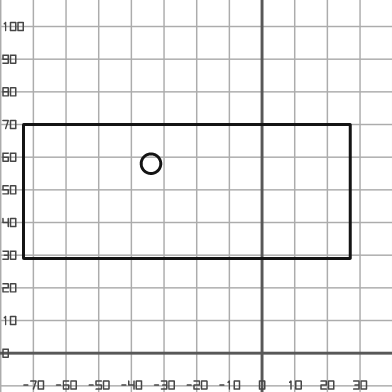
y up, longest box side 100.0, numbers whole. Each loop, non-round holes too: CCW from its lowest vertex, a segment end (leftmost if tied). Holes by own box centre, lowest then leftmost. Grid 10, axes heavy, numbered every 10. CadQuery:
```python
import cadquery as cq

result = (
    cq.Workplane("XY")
    .moveTo(-73.0, 29.0)
    .lineTo(27.0, 29.0)
    .lineTo(27.0, 70.0)
    .lineTo(-73.0, 70.0)
    .close()
    .moveTo(-34.0, 58.0)
    .circle(3.0)
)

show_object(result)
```